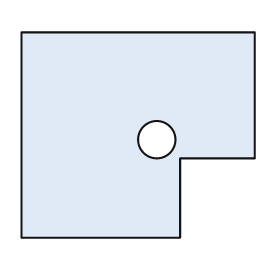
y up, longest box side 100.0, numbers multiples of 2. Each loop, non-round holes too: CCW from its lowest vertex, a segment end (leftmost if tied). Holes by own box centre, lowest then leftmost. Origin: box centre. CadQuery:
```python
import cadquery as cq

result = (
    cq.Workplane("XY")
    .moveTo(-50.0, -44.0)
    .lineTo(18.0, -44.0)
    .lineTo(18.0, -10.0)
    .lineTo(50.0, -10.0)
    .lineTo(50.0, 44.0)
    .lineTo(-50.0, 44.0)
    .close()
    .moveTo(8.0, -2.0)
    .circle(8.0)
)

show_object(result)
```